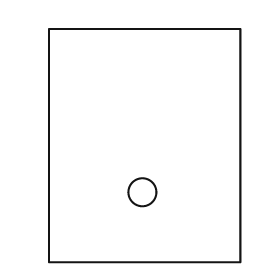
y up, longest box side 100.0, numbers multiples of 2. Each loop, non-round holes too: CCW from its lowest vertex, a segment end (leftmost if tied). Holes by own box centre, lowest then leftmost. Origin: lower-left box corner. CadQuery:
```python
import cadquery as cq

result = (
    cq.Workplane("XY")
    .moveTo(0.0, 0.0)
    .lineTo(82.0, 0.0)
    .lineTo(82.0, 100.0)
    .lineTo(0.0, 100.0)
    .close()
    .moveTo(40.0, 30.0)
    .circle(6.0)
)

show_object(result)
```